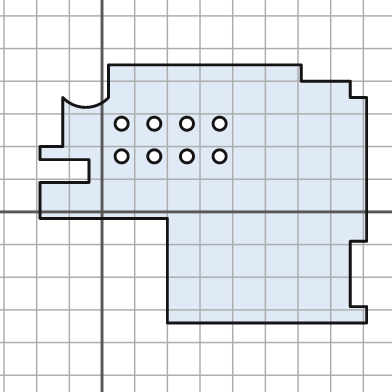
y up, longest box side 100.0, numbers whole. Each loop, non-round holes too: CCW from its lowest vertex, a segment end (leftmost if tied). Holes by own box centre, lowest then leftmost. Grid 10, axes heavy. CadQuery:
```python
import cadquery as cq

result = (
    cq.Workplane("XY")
    .moveTo(20.0, -34.0)
    .lineTo(81.0, -34.0)
    .lineTo(81.0, -29.0)
    .lineTo(76.0, -29.0)
    .lineTo(76.0, -9.0)
    .lineTo(81.0, -9.0)
    .lineTo(81.0, 35.0)
    .lineTo(76.0, 35.0)
    .lineTo(76.0, 40.0)
    .lineTo(61.0, 40.0)
    .lineTo(61.0, 45.0)
    .lineTo(2.0, 45.0)
    .lineTo(2.0, 35.0)
    .threePointArc((-5.0, 32.0), (-12.0, 35.0))
    .lineTo(-12.0, 20.0)
    .lineTo(-19.0, 20.0)
    .lineTo(-19.0, 16.0)
    .lineTo(-4.0, 16.0)
    .lineTo(-4.0, 9.0)
    .lineTo(-19.0, 9.0)
    .lineTo(-19.0, -2.0)
    .lineTo(20.0, -2.0)
    .close()
    .moveTo(6.0, 17.0)
    .circle(2.0)
    .moveTo(16.0, 17.0)
    .circle(2.0)
    .moveTo(26.0, 17.0)
    .circle(2.0)
    .moveTo(36.0, 17.0)
    .circle(2.0)
    .moveTo(6.0, 27.0)
    .circle(2.0)
    .moveTo(16.0, 27.0)
    .circle(2.0)
    .moveTo(26.0, 27.0)
    .circle(2.0)
    .moveTo(36.0, 27.0)
    .circle(2.0)
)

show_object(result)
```